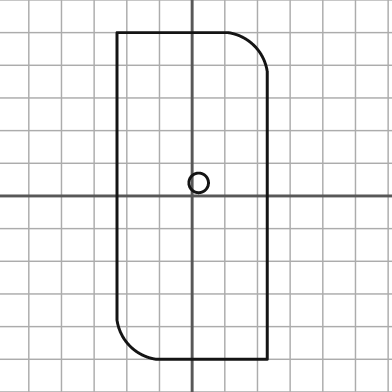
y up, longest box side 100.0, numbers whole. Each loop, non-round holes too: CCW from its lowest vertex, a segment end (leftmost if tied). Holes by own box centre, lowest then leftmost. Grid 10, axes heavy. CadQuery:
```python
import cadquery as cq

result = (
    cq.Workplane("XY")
    .moveTo(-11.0, -50.0)
    .lineTo(23.0, -50.0)
    .lineTo(23.0, 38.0)
    .threePointArc((19.0, 46.0), (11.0, 50.0))
    .lineTo(-23.0, 50.0)
    .lineTo(-23.0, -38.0)
    .threePointArc((-19.0, -46.0), (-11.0, -50.0))
    .close()
    .moveTo(2.0, 4.0)
    .circle(3.0)
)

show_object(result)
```